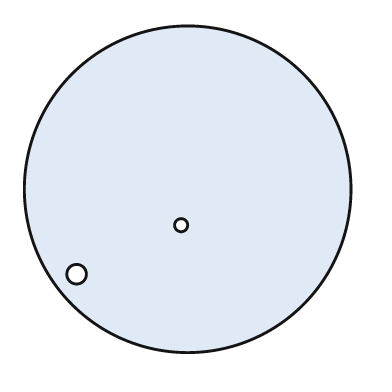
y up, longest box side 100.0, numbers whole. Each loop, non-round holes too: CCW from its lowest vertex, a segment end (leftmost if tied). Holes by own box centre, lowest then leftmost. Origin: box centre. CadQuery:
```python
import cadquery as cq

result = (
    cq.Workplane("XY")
    .moveTo(0.0, 0.0)
    .circle(50.0)
    .moveTo(-34.0, -26.0)
    .circle(3.0)
    .moveTo(-2.0, -11.0)
    .circle(2.0)
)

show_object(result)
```